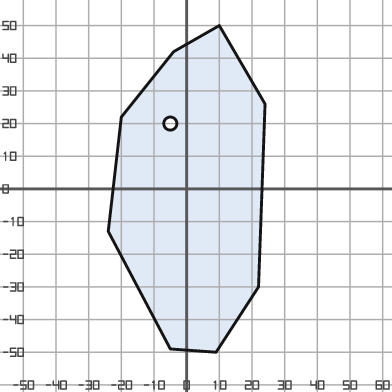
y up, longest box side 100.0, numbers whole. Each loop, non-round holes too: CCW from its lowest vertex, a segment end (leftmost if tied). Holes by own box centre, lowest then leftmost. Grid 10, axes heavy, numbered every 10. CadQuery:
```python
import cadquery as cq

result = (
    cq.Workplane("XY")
    .moveTo(9.0, -50.0)
    .lineTo(22.0, -30.0)
    .lineTo(24.0, 26.0)
    .lineTo(10.0, 50.0)
    .lineTo(-4.0, 42.0)
    .lineTo(-20.0, 22.0)
    .lineTo(-24.0, -13.0)
    .lineTo(-5.0, -49.0)
    .close()
    .moveTo(-5.0, 20.0)
    .circle(2.0)
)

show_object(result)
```